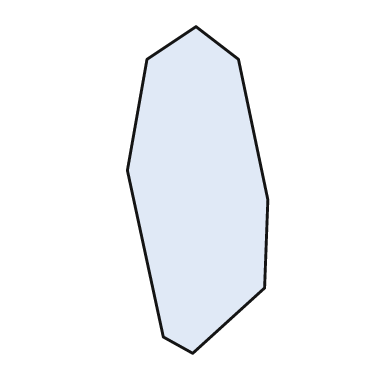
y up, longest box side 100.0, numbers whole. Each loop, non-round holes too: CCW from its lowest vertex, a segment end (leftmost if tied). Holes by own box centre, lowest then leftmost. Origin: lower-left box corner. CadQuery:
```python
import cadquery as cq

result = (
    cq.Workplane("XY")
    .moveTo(20.0, 0.0)
    .lineTo(42.0, 20.0)
    .lineTo(43.0, 47.0)
    .lineTo(34.0, 90.0)
    .lineTo(21.0, 100.0)
    .lineTo(6.0, 90.0)
    .lineTo(0.0, 56.0)
    .lineTo(11.0, 5.0)
    .close()
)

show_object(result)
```